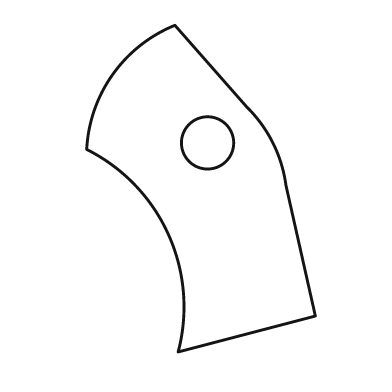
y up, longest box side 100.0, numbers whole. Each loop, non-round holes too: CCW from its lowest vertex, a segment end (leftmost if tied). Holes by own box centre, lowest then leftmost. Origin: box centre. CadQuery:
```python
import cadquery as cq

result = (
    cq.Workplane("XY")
    .moveTo(-7.0, -50.0)
    .lineTo(35.0, -39.0)
    .lineTo(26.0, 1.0)
    .threePointArc((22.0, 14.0), (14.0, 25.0))
    .lineTo(-8.0, 50.0)
    .threePointArc((-27.0, 35.0), (-35.0, 12.0))
    .threePointArc((-10.0, -14.0), (-7.0, -50.0))
    .close()
    .moveTo(2.0, 14.0)
    .circle(8.0)
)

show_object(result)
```